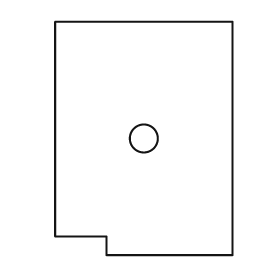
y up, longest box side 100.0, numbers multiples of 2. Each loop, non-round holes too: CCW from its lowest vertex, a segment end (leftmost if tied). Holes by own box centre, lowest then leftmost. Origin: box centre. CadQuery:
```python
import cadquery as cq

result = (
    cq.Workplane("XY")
    .moveTo(-16.0, -50.0)
    .lineTo(38.0, -50.0)
    .lineTo(38.0, 50.0)
    .lineTo(-38.0, 50.0)
    .lineTo(-38.0, -42.0)
    .lineTo(-16.0, -42.0)
    .close()
    .moveTo(0.0, 0.0)
    .circle(6.0)
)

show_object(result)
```